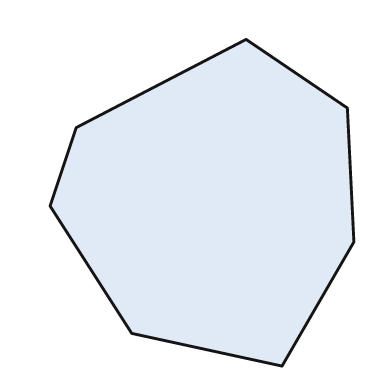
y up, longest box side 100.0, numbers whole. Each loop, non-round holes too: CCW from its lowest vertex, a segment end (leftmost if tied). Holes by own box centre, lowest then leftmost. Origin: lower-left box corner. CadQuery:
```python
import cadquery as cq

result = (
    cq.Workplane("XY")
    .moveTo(71.0, 0.0)
    .lineTo(93.0, 38.0)
    .lineTo(91.0, 79.0)
    .lineTo(60.0, 100.0)
    .lineTo(8.0, 73.0)
    .lineTo(0.0, 49.0)
    .lineTo(25.0, 10.0)
    .close()
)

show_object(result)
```